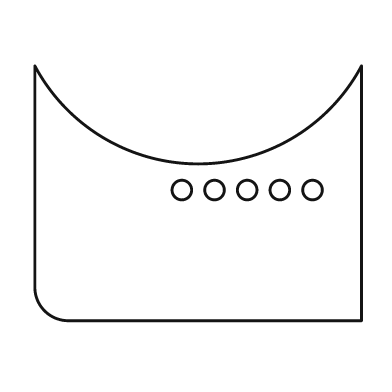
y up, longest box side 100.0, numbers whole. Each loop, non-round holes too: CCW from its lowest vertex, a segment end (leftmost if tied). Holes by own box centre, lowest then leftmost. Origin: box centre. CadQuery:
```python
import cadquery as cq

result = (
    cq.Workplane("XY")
    .moveTo(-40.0, -39.0)
    .lineTo(50.0, -39.0)
    .lineTo(50.0, 39.0)
    .threePointArc((0.0, 9.0), (-50.0, 39.0))
    .lineTo(-50.0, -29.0)
    .threePointArc((-47.0, -36.0), (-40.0, -39.0))
    .close()
    .moveTo(-5.0, 1.0)
    .circle(3.0)
    .moveTo(5.0, 1.0)
    .circle(3.0)
    .moveTo(15.0, 1.0)
    .circle(3.0)
    .moveTo(25.0, 1.0)
    .circle(3.0)
    .moveTo(35.0, 1.0)
    .circle(3.0)
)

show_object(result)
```